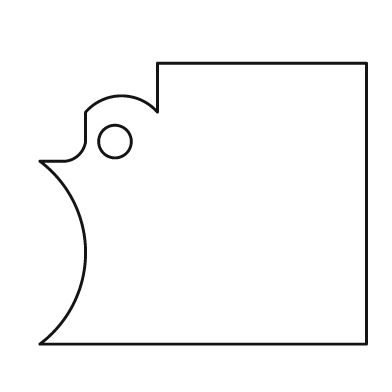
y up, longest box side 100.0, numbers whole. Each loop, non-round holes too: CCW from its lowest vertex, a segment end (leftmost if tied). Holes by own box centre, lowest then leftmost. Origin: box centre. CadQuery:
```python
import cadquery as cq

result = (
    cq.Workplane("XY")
    .moveTo(-50.0, -43.0)
    .lineTo(50.0, -43.0)
    .lineTo(50.0, 43.0)
    .lineTo(-14.0, 43.0)
    .lineTo(-14.0, 28.0)
    .threePointArc((-25.0, 33.0), (-36.0, 28.0))
    .lineTo(-36.0, 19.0)
    .threePointArc((-38.0, 15.0), (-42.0, 13.0))
    .lineTo(-50.0, 13.0)
    .threePointArc((-36.0, -15.0), (-50.0, -43.0))
    .close()
    .moveTo(-27.0, 19.0)
    .circle(5.0)
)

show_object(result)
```